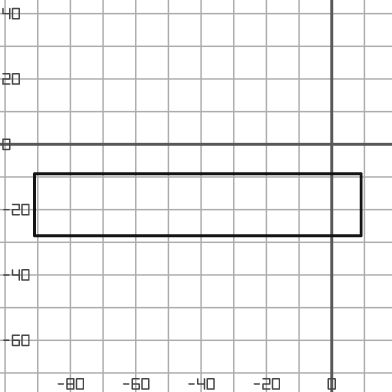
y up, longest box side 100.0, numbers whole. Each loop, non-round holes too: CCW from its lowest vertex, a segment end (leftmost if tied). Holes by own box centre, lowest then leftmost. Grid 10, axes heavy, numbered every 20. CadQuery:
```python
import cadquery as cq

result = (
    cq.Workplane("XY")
    .moveTo(-91.0, -28.0)
    .lineTo(9.0, -28.0)
    .lineTo(9.0, -9.0)
    .lineTo(-91.0, -9.0)
    .close()
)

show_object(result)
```